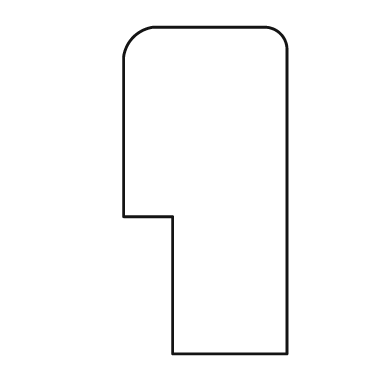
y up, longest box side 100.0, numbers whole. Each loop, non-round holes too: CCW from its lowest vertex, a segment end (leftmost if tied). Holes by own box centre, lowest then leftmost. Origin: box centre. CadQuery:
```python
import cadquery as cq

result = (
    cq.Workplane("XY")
    .moveTo(-10.0, -50.0)
    .lineTo(25.0, -50.0)
    .lineTo(25.0, 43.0)
    .threePointArc((23.0, 48.0), (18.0, 50.0))
    .lineTo(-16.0, 50.0)
    .threePointArc((-22.0, 47.0), (-25.0, 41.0))
    .lineTo(-25.0, -8.0)
    .lineTo(-10.0, -8.0)
    .close()
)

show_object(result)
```